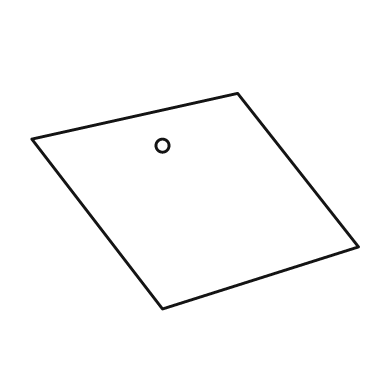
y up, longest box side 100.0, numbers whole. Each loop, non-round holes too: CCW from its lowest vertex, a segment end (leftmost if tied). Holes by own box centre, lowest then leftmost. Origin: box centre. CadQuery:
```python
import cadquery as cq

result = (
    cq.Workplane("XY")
    .moveTo(-10.0, -33.0)
    .lineTo(50.0, -14.0)
    .lineTo(13.0, 33.0)
    .lineTo(-50.0, 19.0)
    .close()
    .moveTo(-10.0, 17.0)
    .circle(2.0)
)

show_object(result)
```